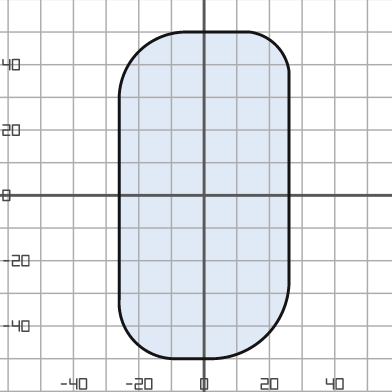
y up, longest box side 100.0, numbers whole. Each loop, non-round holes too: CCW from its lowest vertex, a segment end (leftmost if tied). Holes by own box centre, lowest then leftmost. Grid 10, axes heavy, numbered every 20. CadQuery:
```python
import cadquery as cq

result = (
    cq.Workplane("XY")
    .moveTo(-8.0, -50.0)
    .lineTo(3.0, -50.0)
    .threePointArc((19.0, -43.0), (26.0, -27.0))
    .lineTo(26.0, 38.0)
    .threePointArc((22.0, 46.0), (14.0, 50.0))
    .lineTo(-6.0, 50.0)
    .threePointArc((-20.0, 44.0), (-26.0, 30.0))
    .lineTo(-26.0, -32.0)
    .threePointArc((-21.0, -45.0), (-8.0, -50.0))
    .close()
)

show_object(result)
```